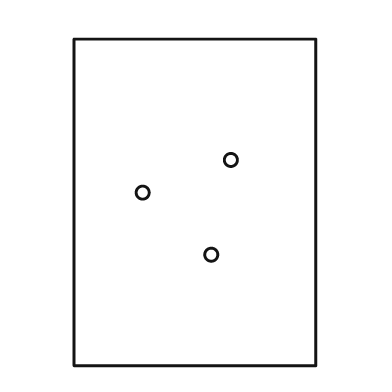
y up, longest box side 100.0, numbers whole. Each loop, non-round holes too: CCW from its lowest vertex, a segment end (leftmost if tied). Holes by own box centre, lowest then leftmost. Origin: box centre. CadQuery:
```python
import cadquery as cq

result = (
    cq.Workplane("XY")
    .moveTo(-37.0, -50.0)
    .lineTo(37.0, -50.0)
    .lineTo(37.0, 50.0)
    .lineTo(-37.0, 50.0)
    .close()
    .moveTo(5.0, -16.0)
    .circle(2.0)
    .moveTo(-16.0, 3.0)
    .circle(2.0)
    .moveTo(11.0, 13.0)
    .circle(2.0)
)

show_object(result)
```